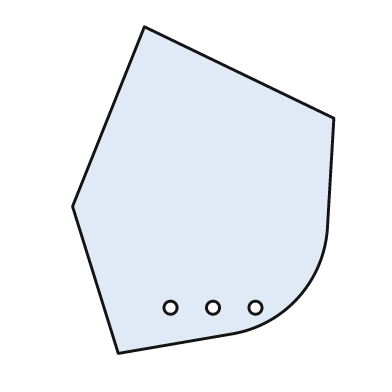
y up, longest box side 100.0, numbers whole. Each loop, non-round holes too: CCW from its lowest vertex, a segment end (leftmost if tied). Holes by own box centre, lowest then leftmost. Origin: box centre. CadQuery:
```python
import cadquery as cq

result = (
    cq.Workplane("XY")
    .moveTo(-26.0, -50.0)
    .lineTo(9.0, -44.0)
    .threePointArc((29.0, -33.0), (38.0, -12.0))
    .lineTo(40.0, 22.0)
    .lineTo(-18.0, 50.0)
    .lineTo(-40.0, -5.0)
    .close()
    .moveTo(-10.0, -36.0)
    .circle(2.0)
    .moveTo(3.0, -36.0)
    .circle(2.0)
    .moveTo(16.0, -36.0)
    .circle(2.0)
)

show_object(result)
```